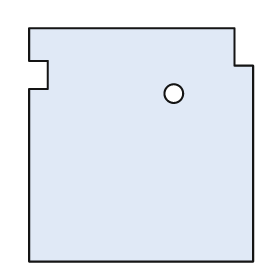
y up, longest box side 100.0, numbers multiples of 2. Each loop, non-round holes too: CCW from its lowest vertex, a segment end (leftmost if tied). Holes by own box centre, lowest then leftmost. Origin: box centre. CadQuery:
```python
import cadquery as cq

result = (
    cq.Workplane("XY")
    .moveTo(-48.0, -50.0)
    .lineTo(48.0, -50.0)
    .lineTo(48.0, 34.0)
    .lineTo(40.0, 34.0)
    .lineTo(40.0, 50.0)
    .lineTo(-48.0, 50.0)
    .lineTo(-48.0, 36.0)
    .lineTo(-40.0, 36.0)
    .lineTo(-40.0, 24.0)
    .lineTo(-48.0, 24.0)
    .close()
    .moveTo(14.0, 22.0)
    .circle(4.0)
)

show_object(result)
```